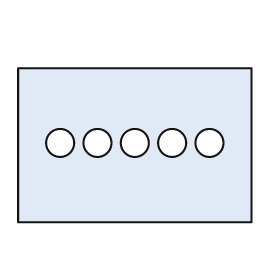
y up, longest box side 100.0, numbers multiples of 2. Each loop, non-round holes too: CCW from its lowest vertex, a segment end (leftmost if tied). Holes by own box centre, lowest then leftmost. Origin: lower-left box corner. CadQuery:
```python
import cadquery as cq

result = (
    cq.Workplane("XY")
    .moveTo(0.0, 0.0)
    .lineTo(100.0, 0.0)
    .lineTo(100.0, 66.0)
    .lineTo(0.0, 66.0)
    .close()
    .moveTo(18.0, 34.0)
    .circle(6.0)
    .moveTo(34.0, 34.0)
    .circle(6.0)
    .moveTo(50.0, 34.0)
    .circle(6.0)
    .moveTo(66.0, 34.0)
    .circle(6.0)
    .moveTo(82.0, 34.0)
    .circle(6.0)
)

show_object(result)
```